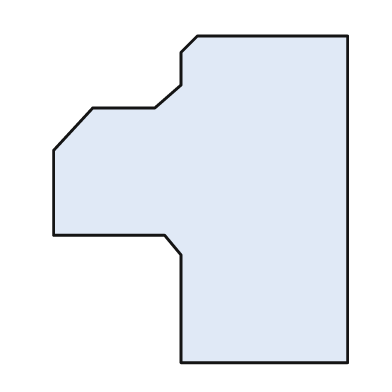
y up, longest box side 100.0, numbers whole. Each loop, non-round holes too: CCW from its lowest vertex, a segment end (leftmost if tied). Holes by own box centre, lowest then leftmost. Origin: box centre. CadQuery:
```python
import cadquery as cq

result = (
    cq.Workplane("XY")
    .moveTo(-6.0, -50.0)
    .lineTo(45.0, -50.0)
    .lineTo(45.0, 50.0)
    .lineTo(-1.0, 50.0)
    .lineTo(-6.0, 45.0)
    .lineTo(-6.0, 35.0)
    .lineTo(-14.0, 28.0)
    .lineTo(-33.0, 28.0)
    .lineTo(-45.0, 15.0)
    .lineTo(-45.0, -11.0)
    .lineTo(-11.0, -11.0)
    .lineTo(-6.0, -17.0)
    .close()
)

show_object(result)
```